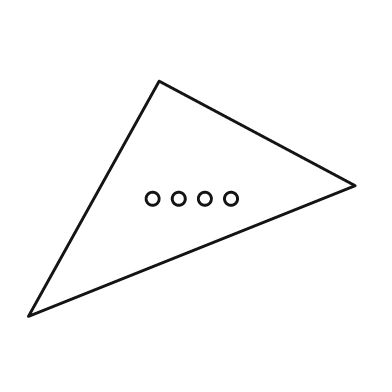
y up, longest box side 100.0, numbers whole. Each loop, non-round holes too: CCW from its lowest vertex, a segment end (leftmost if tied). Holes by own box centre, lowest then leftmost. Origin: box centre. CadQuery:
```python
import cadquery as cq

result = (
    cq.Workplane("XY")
    .moveTo(-50.0, -36.0)
    .lineTo(50.0, 4.0)
    .lineTo(-10.0, 36.0)
    .close()
    .moveTo(-12.0, 0.0)
    .circle(2.0)
    .moveTo(-4.0, 0.0)
    .circle(2.0)
    .moveTo(4.0, 0.0)
    .circle(2.0)
    .moveTo(12.0, 0.0)
    .circle(2.0)
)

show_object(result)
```